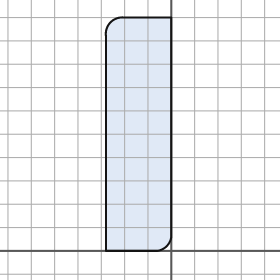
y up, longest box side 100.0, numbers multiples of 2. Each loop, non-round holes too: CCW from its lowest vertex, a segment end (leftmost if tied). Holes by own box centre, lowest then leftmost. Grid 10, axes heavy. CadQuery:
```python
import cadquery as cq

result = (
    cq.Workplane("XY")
    .moveTo(-28.0, 0.0)
    .lineTo(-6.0, 0.0)
    .threePointArc((-2.0, 2.0), (0.0, 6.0))
    .lineTo(0.0, 100.0)
    .lineTo(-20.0, 100.0)
    .threePointArc((-26.0, 98.0), (-28.0, 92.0))
    .close()
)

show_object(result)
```